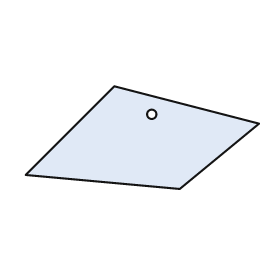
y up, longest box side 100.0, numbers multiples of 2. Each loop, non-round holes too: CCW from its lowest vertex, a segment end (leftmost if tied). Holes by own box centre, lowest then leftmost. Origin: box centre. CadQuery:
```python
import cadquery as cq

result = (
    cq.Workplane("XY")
    .moveTo(16.0, -22.0)
    .lineTo(50.0, 6.0)
    .lineTo(-12.0, 22.0)
    .lineTo(-50.0, -16.0)
    .close()
    .moveTo(4.0, 10.0)
    .circle(2.0)
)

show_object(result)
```